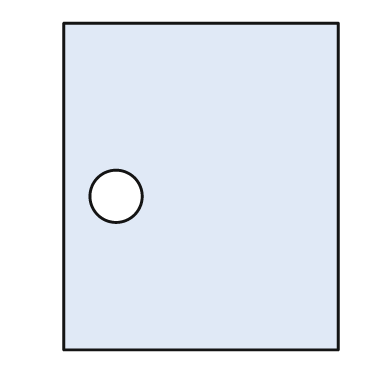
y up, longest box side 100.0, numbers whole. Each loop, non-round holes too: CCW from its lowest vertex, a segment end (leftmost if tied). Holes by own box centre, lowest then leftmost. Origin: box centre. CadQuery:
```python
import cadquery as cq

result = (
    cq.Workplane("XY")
    .moveTo(-42.0, -50.0)
    .lineTo(42.0, -50.0)
    .lineTo(42.0, 50.0)
    .lineTo(-42.0, 50.0)
    .close()
    .moveTo(-26.0, -3.0)
    .circle(8.0)
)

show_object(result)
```